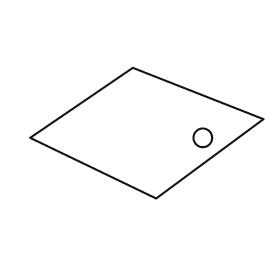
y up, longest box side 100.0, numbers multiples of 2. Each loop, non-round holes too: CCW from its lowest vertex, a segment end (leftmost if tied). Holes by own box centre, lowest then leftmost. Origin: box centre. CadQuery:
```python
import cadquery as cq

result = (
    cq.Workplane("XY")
    .moveTo(4.0, -28.0)
    .lineTo(50.0, 6.0)
    .lineTo(-6.0, 28.0)
    .lineTo(-50.0, -2.0)
    .close()
    .moveTo(24.0, -2.0)
    .circle(4.0)
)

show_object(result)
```